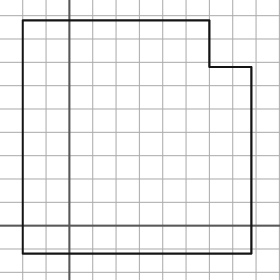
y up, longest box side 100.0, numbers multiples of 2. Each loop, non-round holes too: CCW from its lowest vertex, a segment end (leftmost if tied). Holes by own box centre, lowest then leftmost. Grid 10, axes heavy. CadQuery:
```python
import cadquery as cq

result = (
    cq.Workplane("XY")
    .moveTo(-20.0, -12.0)
    .lineTo(78.0, -12.0)
    .lineTo(78.0, 68.0)
    .lineTo(60.0, 68.0)
    .lineTo(60.0, 88.0)
    .lineTo(-20.0, 88.0)
    .close()
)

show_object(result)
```